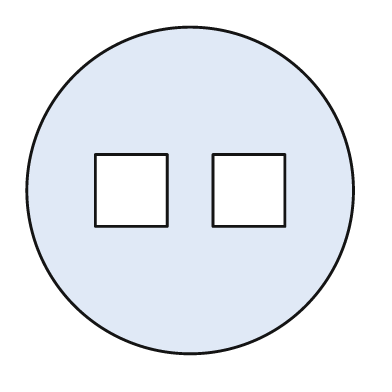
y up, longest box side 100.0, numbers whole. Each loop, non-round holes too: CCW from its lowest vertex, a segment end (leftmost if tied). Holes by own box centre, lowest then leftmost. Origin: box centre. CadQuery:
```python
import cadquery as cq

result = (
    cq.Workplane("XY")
    .moveTo(0.0, 0.0)
    .circle(50.0)
    .moveTo(-29.0, -11.0)
    .lineTo(-7.0, -11.0)
    .lineTo(-7.0, 11.0)
    .lineTo(-29.0, 11.0)
    .close()
    .moveTo(7.0, -11.0)
    .lineTo(29.0, -11.0)
    .lineTo(29.0, 11.0)
    .lineTo(7.0, 11.0)
    .close()
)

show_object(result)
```